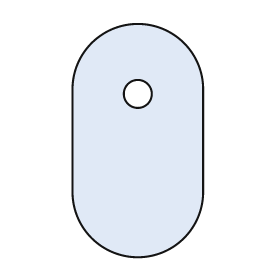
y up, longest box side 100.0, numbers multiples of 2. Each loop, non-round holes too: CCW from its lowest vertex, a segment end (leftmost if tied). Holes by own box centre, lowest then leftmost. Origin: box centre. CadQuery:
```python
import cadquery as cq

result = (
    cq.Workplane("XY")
    .moveTo(-28.0, -22.0)
    .threePointArc((0.0, -50.0), (28.0, -22.0))
    .lineTo(28.0, 22.0)
    .threePointArc((0.0, 50.0), (-28.0, 22.0))
    .close()
    .moveTo(0.0, 20.0)
    .circle(6.0)
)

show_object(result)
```